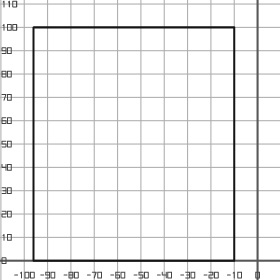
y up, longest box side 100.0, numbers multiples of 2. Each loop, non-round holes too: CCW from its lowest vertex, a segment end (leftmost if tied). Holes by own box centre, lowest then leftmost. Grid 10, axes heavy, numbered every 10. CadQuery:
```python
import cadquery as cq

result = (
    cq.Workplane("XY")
    .moveTo(-96.0, 0.0)
    .lineTo(-10.0, 0.0)
    .lineTo(-10.0, 100.0)
    .lineTo(-96.0, 100.0)
    .close()
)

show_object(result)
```